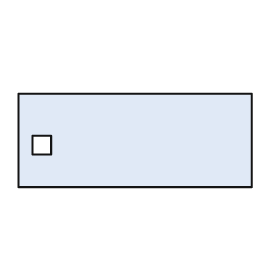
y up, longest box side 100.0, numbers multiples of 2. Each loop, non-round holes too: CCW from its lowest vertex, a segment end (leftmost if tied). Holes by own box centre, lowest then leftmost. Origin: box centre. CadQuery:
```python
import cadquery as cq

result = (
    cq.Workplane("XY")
    .moveTo(-50.0, -20.0)
    .lineTo(50.0, -20.0)
    .lineTo(50.0, 20.0)
    .lineTo(-50.0, 20.0)
    .close()
    .moveTo(-44.0, -6.0)
    .lineTo(-36.0, -6.0)
    .lineTo(-36.0, 2.0)
    .lineTo(-44.0, 2.0)
    .close()
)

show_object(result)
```